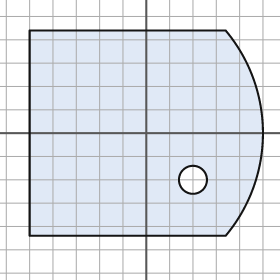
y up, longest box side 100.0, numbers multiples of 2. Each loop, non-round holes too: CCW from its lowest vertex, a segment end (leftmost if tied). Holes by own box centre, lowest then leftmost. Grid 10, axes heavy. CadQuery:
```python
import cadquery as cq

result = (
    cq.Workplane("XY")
    .moveTo(-50.0, -44.0)
    .lineTo(34.0, -44.0)
    .threePointArc((50.0, 0.0), (34.0, 44.0))
    .lineTo(-50.0, 44.0)
    .close()
    .moveTo(20.0, -20.0)
    .circle(6.0)
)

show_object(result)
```